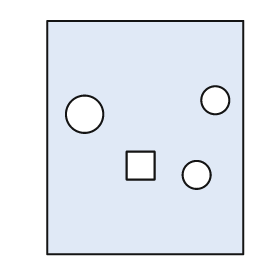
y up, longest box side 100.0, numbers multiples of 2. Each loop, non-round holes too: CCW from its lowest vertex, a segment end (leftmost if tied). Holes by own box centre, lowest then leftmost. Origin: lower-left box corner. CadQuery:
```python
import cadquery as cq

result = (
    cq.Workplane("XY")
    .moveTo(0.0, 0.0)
    .lineTo(84.0, 0.0)
    .lineTo(84.0, 100.0)
    .lineTo(0.0, 100.0)
    .close()
    .moveTo(64.0, 34.0)
    .circle(6.0)
    .moveTo(34.0, 32.0)
    .lineTo(46.0, 32.0)
    .lineTo(46.0, 44.0)
    .lineTo(34.0, 44.0)
    .close()
    .moveTo(16.0, 60.0)
    .circle(8.0)
    .moveTo(72.0, 66.0)
    .circle(6.0)
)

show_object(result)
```